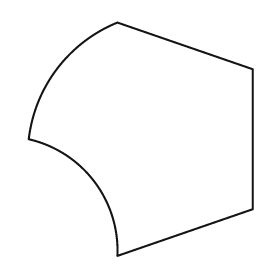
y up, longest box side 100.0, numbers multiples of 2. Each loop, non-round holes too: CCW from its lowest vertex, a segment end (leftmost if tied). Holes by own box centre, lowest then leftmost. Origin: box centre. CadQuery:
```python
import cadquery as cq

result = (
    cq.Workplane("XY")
    .moveTo(-10.0, -50.0)
    .lineTo(48.0, -30.0)
    .lineTo(48.0, 30.0)
    .lineTo(-10.0, 50.0)
    .threePointArc((-36.0, 30.0), (-48.0, 0.0))
    .threePointArc((-20.0, -18.0), (-10.0, -50.0))
    .close()
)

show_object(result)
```